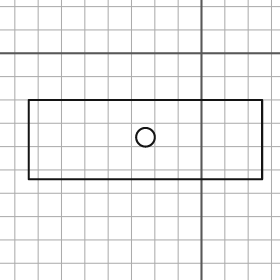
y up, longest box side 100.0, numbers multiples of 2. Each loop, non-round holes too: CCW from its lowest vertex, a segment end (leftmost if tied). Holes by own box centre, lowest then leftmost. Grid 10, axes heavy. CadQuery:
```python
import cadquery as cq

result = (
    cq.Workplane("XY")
    .moveTo(-74.0, -54.0)
    .lineTo(26.0, -54.0)
    .lineTo(26.0, -20.0)
    .lineTo(-74.0, -20.0)
    .close()
    .moveTo(-24.0, -36.0)
    .circle(4.0)
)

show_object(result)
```